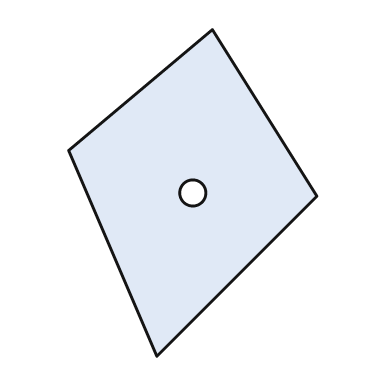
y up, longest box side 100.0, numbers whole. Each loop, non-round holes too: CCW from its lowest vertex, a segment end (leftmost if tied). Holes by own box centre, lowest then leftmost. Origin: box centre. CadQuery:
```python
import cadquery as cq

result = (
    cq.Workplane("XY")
    .moveTo(-11.0, -50.0)
    .lineTo(38.0, -1.0)
    .lineTo(6.0, 50.0)
    .lineTo(-38.0, 13.0)
    .close()
    .moveTo(0.0, 0.0)
    .circle(4.0)
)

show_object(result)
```